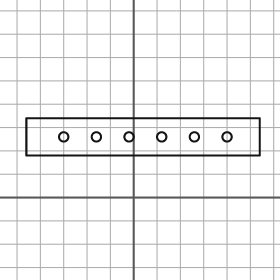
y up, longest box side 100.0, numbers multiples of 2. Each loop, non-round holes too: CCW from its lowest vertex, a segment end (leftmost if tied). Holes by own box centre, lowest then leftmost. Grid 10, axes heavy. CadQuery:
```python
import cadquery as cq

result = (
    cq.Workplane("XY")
    .moveTo(-46.0, 18.0)
    .lineTo(54.0, 18.0)
    .lineTo(54.0, 34.0)
    .lineTo(-46.0, 34.0)
    .close()
    .moveTo(-30.0, 26.0)
    .circle(2.0)
    .moveTo(-16.0, 26.0)
    .circle(2.0)
    .moveTo(-2.0, 26.0)
    .circle(2.0)
    .moveTo(12.0, 26.0)
    .circle(2.0)
    .moveTo(26.0, 26.0)
    .circle(2.0)
    .moveTo(40.0, 26.0)
    .circle(2.0)
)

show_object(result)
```